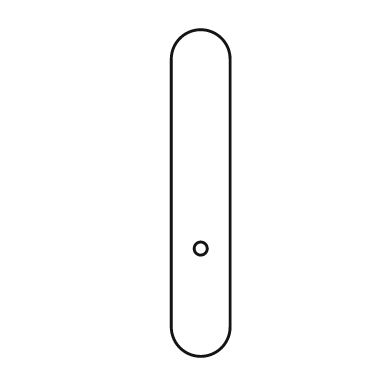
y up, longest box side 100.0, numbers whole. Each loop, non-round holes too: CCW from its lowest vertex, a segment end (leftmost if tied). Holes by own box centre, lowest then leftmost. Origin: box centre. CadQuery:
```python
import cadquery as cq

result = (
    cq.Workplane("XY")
    .moveTo(-9.0, -41.0)
    .threePointArc((0.0, -50.0), (9.0, -41.0))
    .lineTo(9.0, 41.0)
    .threePointArc((0.0, 50.0), (-9.0, 41.0))
    .close()
    .moveTo(0.0, -17.0)
    .circle(2.0)
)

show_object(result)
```